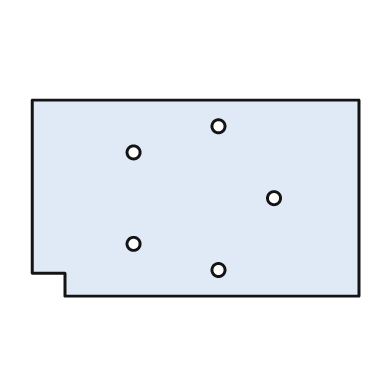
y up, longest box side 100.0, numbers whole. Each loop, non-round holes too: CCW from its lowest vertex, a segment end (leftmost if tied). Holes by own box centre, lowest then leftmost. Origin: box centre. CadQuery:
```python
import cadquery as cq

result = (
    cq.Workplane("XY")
    .moveTo(-40.0, -30.0)
    .lineTo(50.0, -30.0)
    .lineTo(50.0, 30.0)
    .lineTo(-50.0, 30.0)
    .lineTo(-50.0, -23.0)
    .lineTo(-40.0, -23.0)
    .close()
    .moveTo(7.0, -22.0)
    .circle(2.0)
    .moveTo(-19.0, -14.0)
    .circle(2.0)
    .moveTo(24.0, 0.0)
    .circle(2.0)
    .moveTo(-19.0, 14.0)
    .circle(2.0)
    .moveTo(7.0, 22.0)
    .circle(2.0)
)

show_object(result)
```